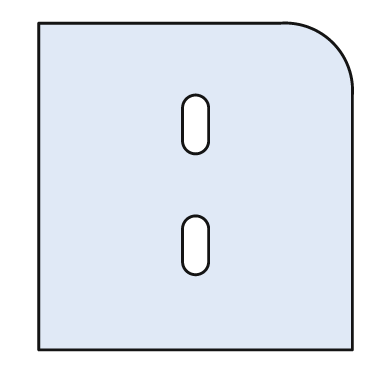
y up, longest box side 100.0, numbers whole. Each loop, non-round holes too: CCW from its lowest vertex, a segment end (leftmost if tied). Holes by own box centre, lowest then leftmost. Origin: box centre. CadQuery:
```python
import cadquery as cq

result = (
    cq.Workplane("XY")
    .moveTo(-48.0, -50.0)
    .lineTo(48.0, -50.0)
    .lineTo(48.0, 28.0)
    .threePointArc((42.0, 44.0), (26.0, 50.0))
    .lineTo(-48.0, 50.0)
    .close()
    .moveTo(-4.0, -23.0)
    .threePointArc((0.0, -27.0), (4.0, -23.0))
    .lineTo(4.0, -13.0)
    .threePointArc((0.0, -9.0), (-4.0, -13.0))
    .close()
    .moveTo(-4.0, 14.0)
    .threePointArc((0.0, 10.0), (4.0, 14.0))
    .lineTo(4.0, 24.0)
    .threePointArc((0.0, 28.0), (-4.0, 24.0))
    .close()
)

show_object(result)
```